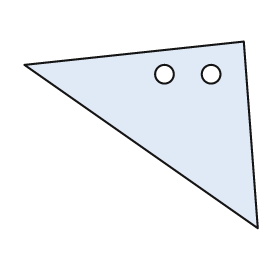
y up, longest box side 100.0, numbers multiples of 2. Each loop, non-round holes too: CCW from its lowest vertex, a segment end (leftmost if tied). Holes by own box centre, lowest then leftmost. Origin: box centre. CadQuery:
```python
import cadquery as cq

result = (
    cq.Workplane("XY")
    .moveTo(50.0, -40.0)
    .lineTo(44.0, 40.0)
    .lineTo(-50.0, 30.0)
    .close()
    .moveTo(10.0, 26.0)
    .circle(4.0)
    .moveTo(30.0, 26.0)
    .circle(4.0)
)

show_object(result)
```